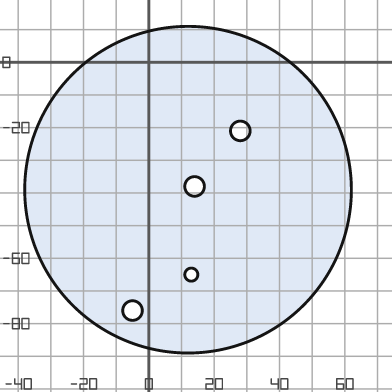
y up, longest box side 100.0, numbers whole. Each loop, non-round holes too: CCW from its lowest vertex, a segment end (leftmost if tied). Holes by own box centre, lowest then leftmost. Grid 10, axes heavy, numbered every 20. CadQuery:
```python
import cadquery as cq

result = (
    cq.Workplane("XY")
    .moveTo(12.0, -39.0)
    .circle(50.0)
    .moveTo(-5.0, -76.0)
    .circle(3.0)
    .moveTo(13.0, -65.0)
    .circle(2.0)
    .moveTo(14.0, -38.0)
    .circle(3.0)
    .moveTo(28.0, -21.0)
    .circle(3.0)
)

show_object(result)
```